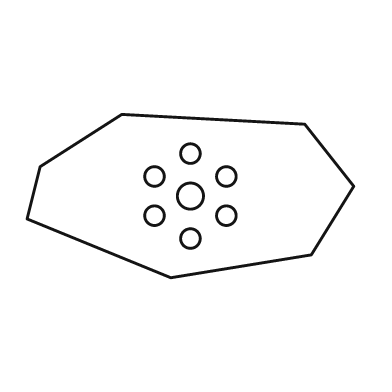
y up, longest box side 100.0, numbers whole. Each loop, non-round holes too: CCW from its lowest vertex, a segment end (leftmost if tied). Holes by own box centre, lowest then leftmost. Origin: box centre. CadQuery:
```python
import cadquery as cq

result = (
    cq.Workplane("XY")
    .moveTo(-6.0, -25.0)
    .lineTo(37.0, -18.0)
    .lineTo(50.0, 3.0)
    .lineTo(35.0, 22.0)
    .lineTo(-21.0, 25.0)
    .lineTo(-46.0, 9.0)
    .lineTo(-50.0, -7.0)
    .close()
    .moveTo(0.0, -13.0)
    .circle(3.0)
    .moveTo(-11.0, -6.0)
    .circle(3.0)
    .moveTo(11.0, -6.0)
    .circle(3.0)
    .moveTo(0.0, 0.0)
    .circle(4.0)
    .moveTo(-11.0, 6.0)
    .circle(3.0)
    .moveTo(11.0, 6.0)
    .circle(3.0)
    .moveTo(0.0, 13.0)
    .circle(3.0)
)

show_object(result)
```